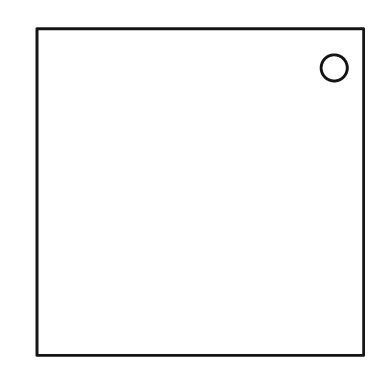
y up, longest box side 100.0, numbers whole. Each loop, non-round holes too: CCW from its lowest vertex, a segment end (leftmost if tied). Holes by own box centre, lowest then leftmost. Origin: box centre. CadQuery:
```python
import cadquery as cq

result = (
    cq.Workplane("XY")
    .moveTo(-50.0, -50.0)
    .lineTo(50.0, -50.0)
    .lineTo(50.0, 50.0)
    .lineTo(-50.0, 50.0)
    .close()
    .moveTo(41.0, 38.0)
    .circle(4.0)
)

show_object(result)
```